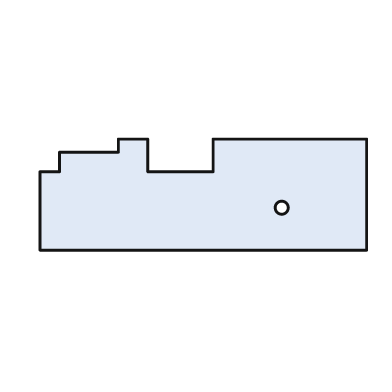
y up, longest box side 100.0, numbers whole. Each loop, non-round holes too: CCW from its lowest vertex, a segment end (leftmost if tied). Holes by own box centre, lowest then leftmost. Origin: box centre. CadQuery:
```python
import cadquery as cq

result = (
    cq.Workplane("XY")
    .moveTo(-50.0, -17.0)
    .lineTo(50.0, -17.0)
    .lineTo(50.0, 17.0)
    .lineTo(3.0, 17.0)
    .lineTo(3.0, 7.0)
    .lineTo(-17.0, 7.0)
    .lineTo(-17.0, 17.0)
    .lineTo(-26.0, 17.0)
    .lineTo(-26.0, 13.0)
    .lineTo(-44.0, 13.0)
    .lineTo(-44.0, 7.0)
    .lineTo(-50.0, 7.0)
    .close()
    .moveTo(24.0, -4.0)
    .circle(2.0)
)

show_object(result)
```